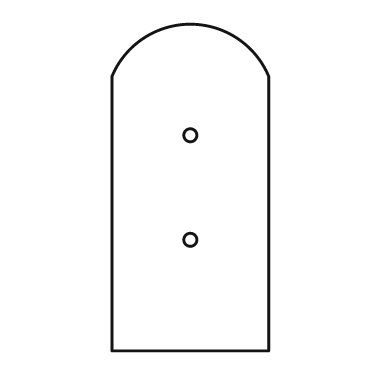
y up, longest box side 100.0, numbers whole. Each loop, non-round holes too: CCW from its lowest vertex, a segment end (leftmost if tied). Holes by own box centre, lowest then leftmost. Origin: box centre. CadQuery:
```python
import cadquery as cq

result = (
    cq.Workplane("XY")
    .moveTo(-24.0, -50.0)
    .lineTo(24.0, -50.0)
    .lineTo(24.0, 34.0)
    .threePointArc((0.0, 50.0), (-24.0, 34.0))
    .close()
    .moveTo(0.0, -16.0)
    .circle(2.0)
    .moveTo(0.0, 16.0)
    .circle(2.0)
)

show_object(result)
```